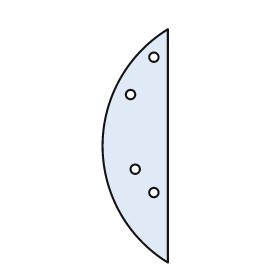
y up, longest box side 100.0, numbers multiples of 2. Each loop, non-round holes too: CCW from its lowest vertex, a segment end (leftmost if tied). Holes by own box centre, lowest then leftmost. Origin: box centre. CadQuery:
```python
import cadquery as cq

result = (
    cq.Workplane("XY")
    .moveTo(14.0, -50.0)
    .lineTo(14.0, 50.0)
    .threePointArc((-14.0, 0.0), (14.0, -50.0))
    .close()
    .moveTo(8.0, -20.0)
    .circle(2.0)
    .moveTo(0.0, -10.0)
    .circle(2.0)
    .moveTo(-2.0, 22.0)
    .circle(2.0)
    .moveTo(8.0, 38.0)
    .circle(2.0)
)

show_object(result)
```